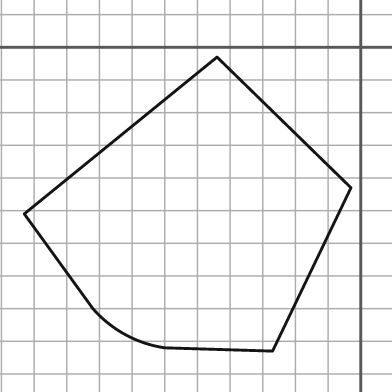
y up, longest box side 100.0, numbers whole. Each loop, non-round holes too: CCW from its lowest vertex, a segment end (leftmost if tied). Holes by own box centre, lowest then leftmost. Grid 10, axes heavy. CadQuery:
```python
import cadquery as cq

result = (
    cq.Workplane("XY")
    .moveTo(-27.0, -93.0)
    .lineTo(-3.0, -43.0)
    .lineTo(-44.0, -3.0)
    .lineTo(-103.0, -51.0)
    .lineTo(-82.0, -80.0)
    .threePointArc((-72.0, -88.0), (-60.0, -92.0))
    .close()
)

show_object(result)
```